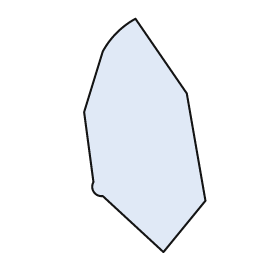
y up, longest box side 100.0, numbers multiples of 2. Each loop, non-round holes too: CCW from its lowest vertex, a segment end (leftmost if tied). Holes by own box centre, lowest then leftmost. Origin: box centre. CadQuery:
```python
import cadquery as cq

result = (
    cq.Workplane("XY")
    .moveTo(8.0, -50.0)
    .lineTo(26.0, -28.0)
    .lineTo(18.0, 18.0)
    .lineTo(-4.0, 50.0)
    .threePointArc((-12.0, 44.0), (-18.0, 36.0))
    .lineTo(-26.0, 10.0)
    .lineTo(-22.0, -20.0)
    .threePointArc((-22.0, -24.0), (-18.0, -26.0))
    .close()
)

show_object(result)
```